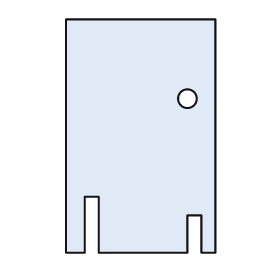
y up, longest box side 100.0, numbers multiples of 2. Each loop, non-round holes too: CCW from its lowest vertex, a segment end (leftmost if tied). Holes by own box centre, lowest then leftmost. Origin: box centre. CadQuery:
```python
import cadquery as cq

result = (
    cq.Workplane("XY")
    .moveTo(-32.0, -50.0)
    .lineTo(-24.0, -50.0)
    .lineTo(-24.0, -26.0)
    .lineTo(-18.0, -26.0)
    .lineTo(-18.0, -50.0)
    .lineTo(20.0, -50.0)
    .lineTo(20.0, -34.0)
    .lineTo(26.0, -34.0)
    .lineTo(26.0, -50.0)
    .lineTo(32.0, -50.0)
    .lineTo(32.0, 50.0)
    .lineTo(-32.0, 50.0)
    .close()
    .moveTo(20.0, 16.0)
    .circle(4.0)
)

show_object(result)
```